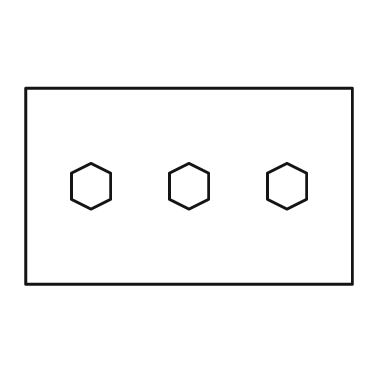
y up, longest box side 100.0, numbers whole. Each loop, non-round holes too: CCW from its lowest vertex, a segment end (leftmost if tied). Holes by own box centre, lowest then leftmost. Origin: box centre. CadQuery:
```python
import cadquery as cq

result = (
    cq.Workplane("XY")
    .moveTo(-50.0, -30.0)
    .lineTo(50.0, -30.0)
    .lineTo(50.0, 30.0)
    .lineTo(-50.0, 30.0)
    .close()
    .moveTo(-30.0, -7.0)
    .lineTo(-24.0, -4.0)
    .lineTo(-24.0, 4.0)
    .lineTo(-30.0, 7.0)
    .lineTo(-36.0, 4.0)
    .lineTo(-36.0, -4.0)
    .close()
    .moveTo(0.0, -7.0)
    .lineTo(6.0, -4.0)
    .lineTo(6.0, 4.0)
    .lineTo(0.0, 7.0)
    .lineTo(-6.0, 4.0)
    .lineTo(-6.0, -4.0)
    .close()
    .moveTo(30.0, -7.0)
    .lineTo(36.0, -4.0)
    .lineTo(36.0, 4.0)
    .lineTo(30.0, 7.0)
    .lineTo(24.0, 4.0)
    .lineTo(24.0, -4.0)
    .close()
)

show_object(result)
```